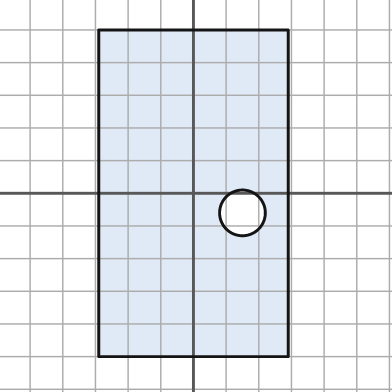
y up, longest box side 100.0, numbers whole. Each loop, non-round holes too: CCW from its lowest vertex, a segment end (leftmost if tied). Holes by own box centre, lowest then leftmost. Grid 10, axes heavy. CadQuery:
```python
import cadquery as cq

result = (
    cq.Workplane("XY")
    .moveTo(-29.0, -50.0)
    .lineTo(29.0, -50.0)
    .lineTo(29.0, 50.0)
    .lineTo(-29.0, 50.0)
    .close()
    .moveTo(15.0, -6.0)
    .circle(7.0)
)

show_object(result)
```